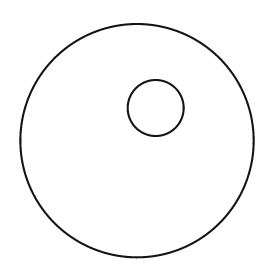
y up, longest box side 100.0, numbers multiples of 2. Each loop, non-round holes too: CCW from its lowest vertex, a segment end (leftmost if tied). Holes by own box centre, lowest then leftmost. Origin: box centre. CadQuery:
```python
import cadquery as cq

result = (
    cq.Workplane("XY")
    .moveTo(0.0, 0.0)
    .circle(50.0)
    .moveTo(8.0, 14.0)
    .circle(12.0)
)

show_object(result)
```